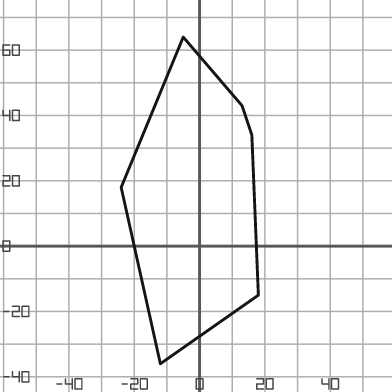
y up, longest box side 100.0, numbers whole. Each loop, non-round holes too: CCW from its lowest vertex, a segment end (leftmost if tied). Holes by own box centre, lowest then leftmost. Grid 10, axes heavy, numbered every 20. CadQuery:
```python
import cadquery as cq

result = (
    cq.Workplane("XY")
    .moveTo(-12.0, -36.0)
    .lineTo(18.0, -15.0)
    .lineTo(16.0, 34.0)
    .lineTo(13.0, 43.0)
    .lineTo(-5.0, 64.0)
    .lineTo(-24.0, 18.0)
    .close()
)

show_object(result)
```